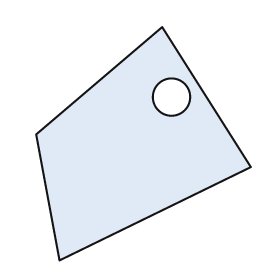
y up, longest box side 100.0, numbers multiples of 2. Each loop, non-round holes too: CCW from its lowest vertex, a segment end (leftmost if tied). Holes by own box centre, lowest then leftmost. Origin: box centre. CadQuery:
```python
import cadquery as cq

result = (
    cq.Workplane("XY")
    .moveTo(-36.0, -50.0)
    .lineTo(46.0, -10.0)
    .lineTo(8.0, 50.0)
    .lineTo(-46.0, 4.0)
    .close()
    .moveTo(12.0, 20.0)
    .circle(8.0)
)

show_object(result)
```